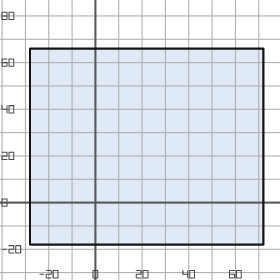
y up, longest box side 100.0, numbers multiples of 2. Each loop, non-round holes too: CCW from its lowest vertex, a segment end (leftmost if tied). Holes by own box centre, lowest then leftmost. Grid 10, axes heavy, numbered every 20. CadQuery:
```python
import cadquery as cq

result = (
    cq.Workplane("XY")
    .moveTo(-28.0, -18.0)
    .lineTo(72.0, -18.0)
    .lineTo(72.0, 66.0)
    .lineTo(-28.0, 66.0)
    .close()
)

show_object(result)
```